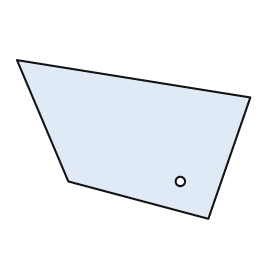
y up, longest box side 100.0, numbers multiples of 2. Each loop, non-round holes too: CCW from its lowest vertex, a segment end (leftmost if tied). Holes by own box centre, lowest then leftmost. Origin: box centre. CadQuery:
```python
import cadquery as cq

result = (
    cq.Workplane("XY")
    .moveTo(32.0, -34.0)
    .lineTo(50.0, 18.0)
    .lineTo(-50.0, 34.0)
    .lineTo(-28.0, -18.0)
    .close()
    .moveTo(20.0, -18.0)
    .circle(2.0)
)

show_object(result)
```